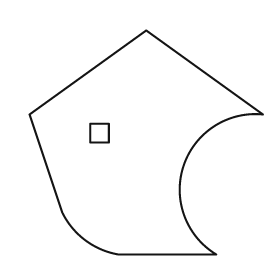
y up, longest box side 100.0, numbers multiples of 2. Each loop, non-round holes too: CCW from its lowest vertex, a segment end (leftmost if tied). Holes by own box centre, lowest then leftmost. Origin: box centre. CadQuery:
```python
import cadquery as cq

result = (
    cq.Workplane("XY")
    .moveTo(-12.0, -48.0)
    .lineTo(30.0, -48.0)
    .threePointArc((16.0, -10.0), (50.0, 12.0))
    .lineTo(0.0, 48.0)
    .lineTo(-50.0, 12.0)
    .lineTo(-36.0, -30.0)
    .threePointArc((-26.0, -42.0), (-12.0, -48.0))
    .close()
    .moveTo(-24.0, 0.0)
    .lineTo(-16.0, 0.0)
    .lineTo(-16.0, 8.0)
    .lineTo(-24.0, 8.0)
    .close()
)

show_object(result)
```